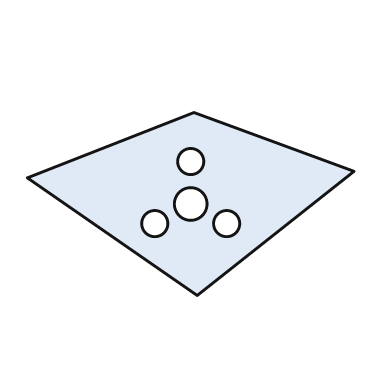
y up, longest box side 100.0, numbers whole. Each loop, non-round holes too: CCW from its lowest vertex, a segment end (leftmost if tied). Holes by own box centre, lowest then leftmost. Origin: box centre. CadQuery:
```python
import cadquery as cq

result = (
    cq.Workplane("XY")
    .moveTo(2.0, -28.0)
    .lineTo(50.0, 10.0)
    .lineTo(1.0, 28.0)
    .lineTo(-50.0, 8.0)
    .close()
    .moveTo(-11.0, -6.0)
    .circle(4.0)
    .moveTo(11.0, -6.0)
    .circle(4.0)
    .moveTo(0.0, 0.0)
    .circle(5.0)
    .moveTo(0.0, 13.0)
    .circle(4.0)
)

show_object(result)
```